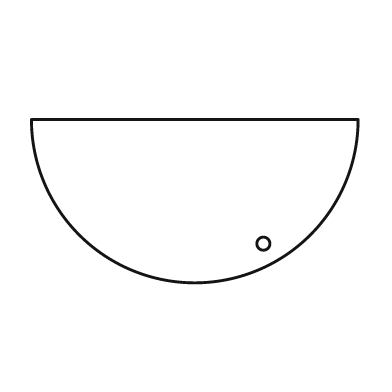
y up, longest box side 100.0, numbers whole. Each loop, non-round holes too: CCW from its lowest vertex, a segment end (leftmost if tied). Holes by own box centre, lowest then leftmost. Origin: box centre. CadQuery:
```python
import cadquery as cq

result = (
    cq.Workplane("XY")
    .moveTo(-50.0, 25.0)
    .threePointArc((0.0, -25.0), (50.0, 25.0))
    .close()
    .moveTo(21.0, -13.0)
    .circle(2.0)
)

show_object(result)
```